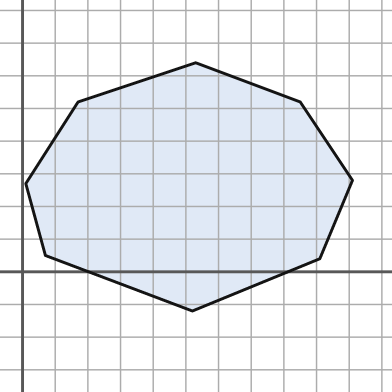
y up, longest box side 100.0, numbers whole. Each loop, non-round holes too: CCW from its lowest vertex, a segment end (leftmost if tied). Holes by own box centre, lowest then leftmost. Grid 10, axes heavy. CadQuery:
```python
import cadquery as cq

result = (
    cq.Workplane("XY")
    .moveTo(52.0, -12.0)
    .lineTo(91.0, 4.0)
    .lineTo(101.0, 28.0)
    .lineTo(85.0, 52.0)
    .lineTo(53.0, 64.0)
    .lineTo(17.0, 52.0)
    .lineTo(1.0, 27.0)
    .lineTo(7.0, 5.0)
    .close()
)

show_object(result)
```